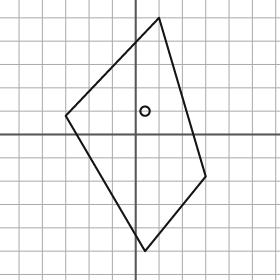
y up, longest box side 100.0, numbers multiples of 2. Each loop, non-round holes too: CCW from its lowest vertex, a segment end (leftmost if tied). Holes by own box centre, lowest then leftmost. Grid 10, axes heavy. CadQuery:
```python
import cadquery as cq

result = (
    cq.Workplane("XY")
    .moveTo(4.0, -50.0)
    .lineTo(30.0, -18.0)
    .lineTo(10.0, 50.0)
    .lineTo(-30.0, 8.0)
    .close()
    .moveTo(4.0, 10.0)
    .circle(2.0)
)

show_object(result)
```